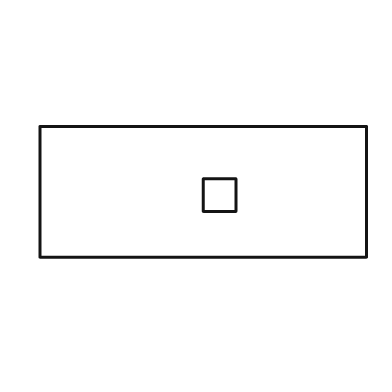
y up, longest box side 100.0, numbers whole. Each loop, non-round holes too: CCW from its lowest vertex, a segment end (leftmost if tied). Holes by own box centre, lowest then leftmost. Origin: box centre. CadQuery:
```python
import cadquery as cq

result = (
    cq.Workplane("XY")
    .moveTo(-50.0, -20.0)
    .lineTo(50.0, -20.0)
    .lineTo(50.0, 20.0)
    .lineTo(-50.0, 20.0)
    .close()
    .moveTo(0.0, -6.0)
    .lineTo(10.0, -6.0)
    .lineTo(10.0, 4.0)
    .lineTo(0.0, 4.0)
    .close()
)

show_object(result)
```